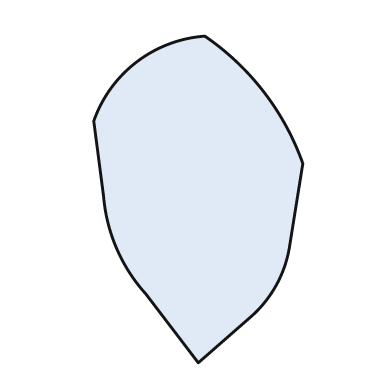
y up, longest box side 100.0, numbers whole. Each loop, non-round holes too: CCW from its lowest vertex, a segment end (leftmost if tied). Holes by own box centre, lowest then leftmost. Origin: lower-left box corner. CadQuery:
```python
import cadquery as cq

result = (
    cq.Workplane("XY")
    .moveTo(32.0, 0.0)
    .lineTo(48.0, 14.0)
    .threePointArc((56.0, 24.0), (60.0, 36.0))
    .lineTo(64.0, 61.0)
    .threePointArc((52.0, 83.0), (34.0, 100.0))
    .threePointArc((13.0, 92.0), (0.0, 74.0))
    .lineTo(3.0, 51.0)
    .threePointArc((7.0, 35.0), (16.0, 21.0))
    .close()
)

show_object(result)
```